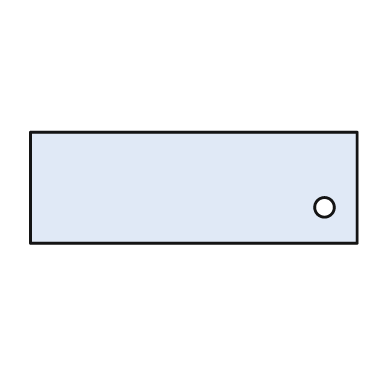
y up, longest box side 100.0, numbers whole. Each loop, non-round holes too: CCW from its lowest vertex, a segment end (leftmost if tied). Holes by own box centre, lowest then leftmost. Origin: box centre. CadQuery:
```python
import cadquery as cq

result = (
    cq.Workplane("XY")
    .moveTo(-50.0, -17.0)
    .lineTo(50.0, -17.0)
    .lineTo(50.0, 17.0)
    .lineTo(-50.0, 17.0)
    .close()
    .moveTo(40.0, -6.0)
    .circle(3.0)
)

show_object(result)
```